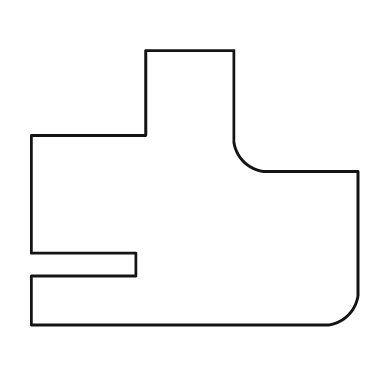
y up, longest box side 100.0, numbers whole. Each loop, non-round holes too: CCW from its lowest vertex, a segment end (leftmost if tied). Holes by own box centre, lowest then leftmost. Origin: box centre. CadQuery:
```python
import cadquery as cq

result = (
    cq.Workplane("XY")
    .moveTo(-50.0, -42.0)
    .lineTo(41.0, -42.0)
    .threePointArc((47.0, -39.0), (50.0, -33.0))
    .lineTo(50.0, 5.0)
    .lineTo(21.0, 5.0)
    .threePointArc((15.0, 8.0), (12.0, 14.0))
    .lineTo(12.0, 42.0)
    .lineTo(-15.0, 42.0)
    .lineTo(-15.0, 16.0)
    .lineTo(-50.0, 16.0)
    .lineTo(-50.0, -20.0)
    .lineTo(-18.0, -20.0)
    .lineTo(-18.0, -27.0)
    .lineTo(-50.0, -27.0)
    .close()
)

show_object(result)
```